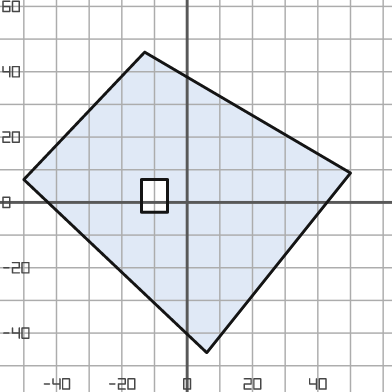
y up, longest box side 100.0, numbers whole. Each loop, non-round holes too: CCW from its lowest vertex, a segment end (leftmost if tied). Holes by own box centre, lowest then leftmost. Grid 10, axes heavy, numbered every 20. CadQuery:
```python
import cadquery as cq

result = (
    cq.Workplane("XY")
    .moveTo(6.0, -46.0)
    .lineTo(50.0, 9.0)
    .lineTo(-13.0, 46.0)
    .lineTo(-50.0, 7.0)
    .close()
    .moveTo(-14.0, -3.0)
    .lineTo(-6.0, -3.0)
    .lineTo(-6.0, 7.0)
    .lineTo(-14.0, 7.0)
    .close()
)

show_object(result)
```